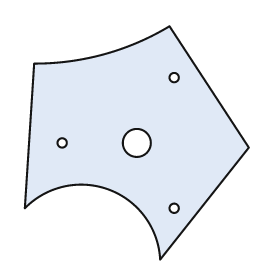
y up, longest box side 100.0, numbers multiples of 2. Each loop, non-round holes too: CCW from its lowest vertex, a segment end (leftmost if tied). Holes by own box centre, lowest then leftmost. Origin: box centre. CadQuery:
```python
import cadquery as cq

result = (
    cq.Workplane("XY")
    .moveTo(10.0, -50.0)
    .lineTo(48.0, -2.0)
    .lineTo(14.0, 50.0)
    .threePointArc((-14.0, 38.0), (-44.0, 34.0))
    .lineTo(-48.0, -28.0)
    .threePointArc((-12.0, -20.0), (10.0, -50.0))
    .close()
    .moveTo(16.0, -28.0)
    .circle(2.0)
    .moveTo(-32.0, 0.0)
    .circle(2.0)
    .moveTo(0.0, 0.0)
    .circle(6.0)
    .moveTo(16.0, 28.0)
    .circle(2.0)
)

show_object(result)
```